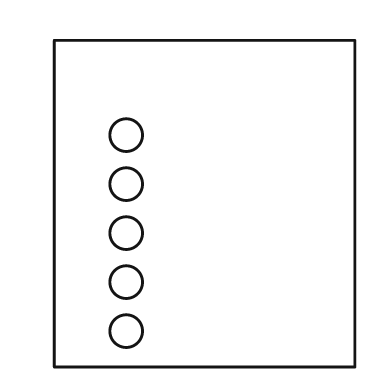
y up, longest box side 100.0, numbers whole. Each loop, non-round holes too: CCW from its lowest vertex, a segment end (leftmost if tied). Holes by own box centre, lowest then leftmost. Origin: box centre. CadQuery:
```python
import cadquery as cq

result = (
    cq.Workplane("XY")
    .moveTo(-46.0, -50.0)
    .lineTo(46.0, -50.0)
    .lineTo(46.0, 50.0)
    .lineTo(-46.0, 50.0)
    .close()
    .moveTo(-24.0, -39.0)
    .circle(5.0)
    .moveTo(-24.0, -24.0)
    .circle(5.0)
    .moveTo(-24.0, -9.0)
    .circle(5.0)
    .moveTo(-24.0, 6.0)
    .circle(5.0)
    .moveTo(-24.0, 21.0)
    .circle(5.0)
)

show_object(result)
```